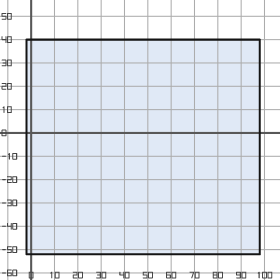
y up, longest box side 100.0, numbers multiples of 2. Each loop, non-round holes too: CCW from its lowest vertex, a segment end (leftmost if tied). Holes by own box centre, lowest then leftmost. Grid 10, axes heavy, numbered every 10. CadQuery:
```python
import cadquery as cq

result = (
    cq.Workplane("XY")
    .moveTo(-2.0, -52.0)
    .lineTo(98.0, -52.0)
    .lineTo(98.0, 40.0)
    .lineTo(-2.0, 40.0)
    .close()
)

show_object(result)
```